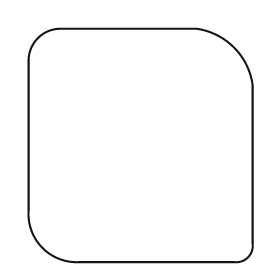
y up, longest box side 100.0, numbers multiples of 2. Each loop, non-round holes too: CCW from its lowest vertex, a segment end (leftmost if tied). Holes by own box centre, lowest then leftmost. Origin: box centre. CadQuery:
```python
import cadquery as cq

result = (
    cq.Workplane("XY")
    .moveTo(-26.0, -50.0)
    .lineTo(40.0, -50.0)
    .threePointArc((46.0, -48.0), (48.0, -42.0))
    .lineTo(48.0, 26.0)
    .threePointArc((40.0, 42.0), (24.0, 50.0))
    .lineTo(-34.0, 50.0)
    .threePointArc((-44.0, 46.0), (-48.0, 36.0))
    .lineTo(-48.0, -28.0)
    .threePointArc((-42.0, -44.0), (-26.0, -50.0))
    .close()
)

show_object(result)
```